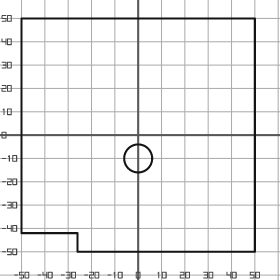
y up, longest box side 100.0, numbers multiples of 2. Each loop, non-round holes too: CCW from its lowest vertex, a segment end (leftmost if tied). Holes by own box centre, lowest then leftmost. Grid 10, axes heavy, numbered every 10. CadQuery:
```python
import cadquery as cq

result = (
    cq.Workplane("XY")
    .moveTo(-26.0, -50.0)
    .lineTo(50.0, -50.0)
    .lineTo(50.0, 50.0)
    .lineTo(-50.0, 50.0)
    .lineTo(-50.0, -42.0)
    .lineTo(-26.0, -42.0)
    .close()
    .moveTo(0.0, -10.0)
    .circle(6.0)
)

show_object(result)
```